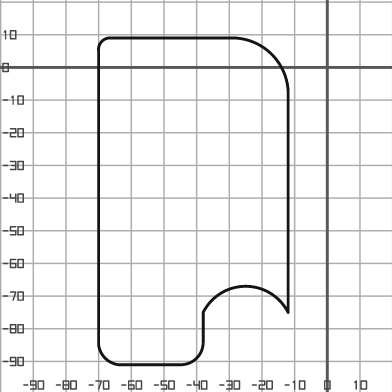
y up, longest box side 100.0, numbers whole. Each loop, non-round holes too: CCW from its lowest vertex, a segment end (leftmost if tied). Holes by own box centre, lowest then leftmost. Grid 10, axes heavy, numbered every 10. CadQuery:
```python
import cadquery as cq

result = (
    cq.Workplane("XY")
    .moveTo(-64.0, -91.0)
    .lineTo(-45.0, -91.0)
    .threePointArc((-40.0, -89.0), (-38.0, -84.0))
    .lineTo(-38.0, -75.0)
    .threePointArc((-25.0, -67.0), (-12.0, -75.0))
    .lineTo(-12.0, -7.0)
    .threePointArc((-17.0, 4.0), (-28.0, 9.0))
    .lineTo(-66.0, 9.0)
    .threePointArc((-69.0, 8.0), (-70.0, 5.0))
    .lineTo(-70.0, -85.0)
    .threePointArc((-68.0, -89.0), (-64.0, -91.0))
    .close()
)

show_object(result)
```